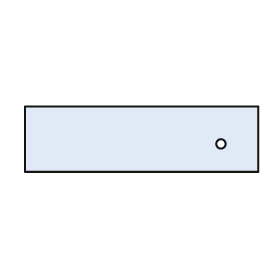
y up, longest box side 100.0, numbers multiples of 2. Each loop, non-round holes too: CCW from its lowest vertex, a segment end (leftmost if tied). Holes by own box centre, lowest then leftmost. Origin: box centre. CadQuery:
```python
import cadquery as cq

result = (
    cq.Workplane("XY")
    .moveTo(-50.0, -14.0)
    .lineTo(50.0, -14.0)
    .lineTo(50.0, 14.0)
    .lineTo(-50.0, 14.0)
    .close()
    .moveTo(34.0, -2.0)
    .circle(2.0)
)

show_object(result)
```